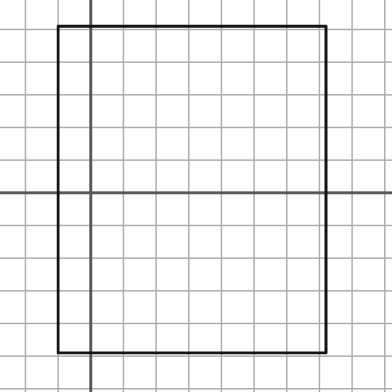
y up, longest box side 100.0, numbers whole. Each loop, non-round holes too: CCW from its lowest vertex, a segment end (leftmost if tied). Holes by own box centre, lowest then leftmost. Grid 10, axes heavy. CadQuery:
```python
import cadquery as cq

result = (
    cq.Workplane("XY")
    .moveTo(-10.0, -49.0)
    .lineTo(72.0, -49.0)
    .lineTo(72.0, 51.0)
    .lineTo(-10.0, 51.0)
    .close()
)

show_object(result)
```